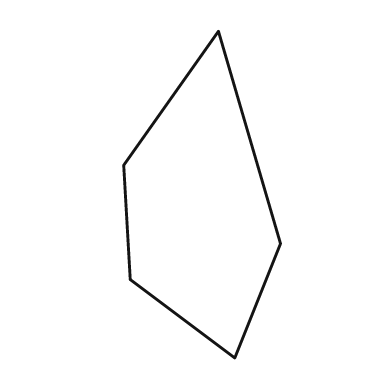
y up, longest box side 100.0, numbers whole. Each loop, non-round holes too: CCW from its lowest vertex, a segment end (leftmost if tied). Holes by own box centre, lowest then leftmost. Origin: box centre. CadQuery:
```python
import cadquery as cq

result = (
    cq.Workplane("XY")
    .moveTo(10.0, -50.0)
    .lineTo(24.0, -15.0)
    .lineTo(5.0, 50.0)
    .lineTo(-24.0, 9.0)
    .lineTo(-22.0, -26.0)
    .close()
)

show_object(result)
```